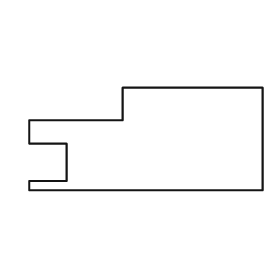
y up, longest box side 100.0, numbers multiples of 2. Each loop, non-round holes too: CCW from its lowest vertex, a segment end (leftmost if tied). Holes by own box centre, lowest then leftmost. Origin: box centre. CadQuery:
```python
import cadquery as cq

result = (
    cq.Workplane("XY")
    .moveTo(-50.0, -22.0)
    .lineTo(50.0, -22.0)
    .lineTo(50.0, 22.0)
    .lineTo(-10.0, 22.0)
    .lineTo(-10.0, 8.0)
    .lineTo(-50.0, 8.0)
    .lineTo(-50.0, -2.0)
    .lineTo(-34.0, -2.0)
    .lineTo(-34.0, -18.0)
    .lineTo(-50.0, -18.0)
    .close()
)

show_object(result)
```